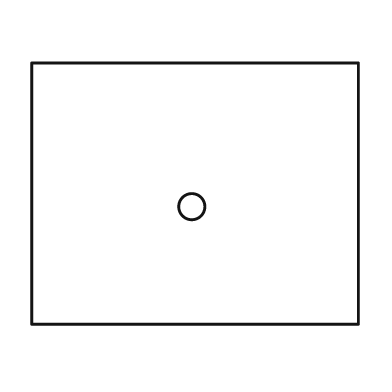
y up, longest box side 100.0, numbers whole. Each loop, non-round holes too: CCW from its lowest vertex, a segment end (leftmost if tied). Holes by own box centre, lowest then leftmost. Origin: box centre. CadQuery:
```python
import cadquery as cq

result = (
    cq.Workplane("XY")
    .moveTo(-50.0, -40.0)
    .lineTo(50.0, -40.0)
    .lineTo(50.0, 40.0)
    .lineTo(-50.0, 40.0)
    .close()
    .moveTo(-1.0, -4.0)
    .circle(4.0)
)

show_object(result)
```